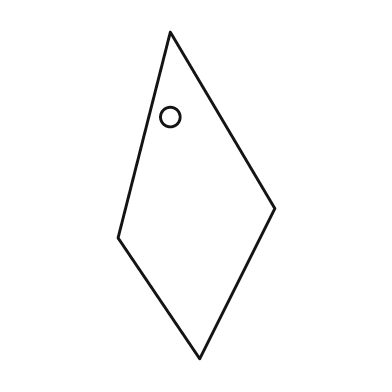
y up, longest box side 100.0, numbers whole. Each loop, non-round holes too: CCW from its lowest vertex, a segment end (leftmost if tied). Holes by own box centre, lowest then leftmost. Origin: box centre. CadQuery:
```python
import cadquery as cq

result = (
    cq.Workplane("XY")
    .moveTo(1.0, -50.0)
    .lineTo(24.0, -4.0)
    .lineTo(-8.0, 50.0)
    .lineTo(-24.0, -13.0)
    .close()
    .moveTo(-8.0, 24.0)
    .circle(3.0)
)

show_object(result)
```